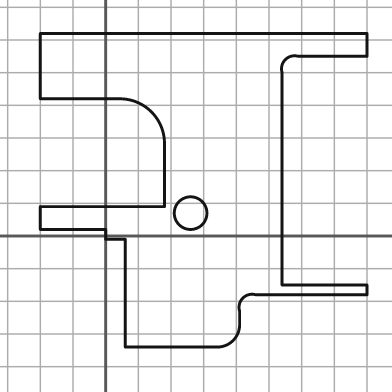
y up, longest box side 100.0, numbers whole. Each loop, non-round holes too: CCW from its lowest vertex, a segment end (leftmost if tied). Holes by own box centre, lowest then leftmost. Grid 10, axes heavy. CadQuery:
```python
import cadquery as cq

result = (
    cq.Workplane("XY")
    .moveTo(6.0, -34.0)
    .lineTo(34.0, -34.0)
    .threePointArc((39.0, -32.0), (41.0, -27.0))
    .lineTo(41.0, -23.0)
    .threePointArc((42.0, -19.0), (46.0, -18.0))
    .lineTo(80.0, -18.0)
    .lineTo(80.0, -15.0)
    .lineTo(54.0, -15.0)
    .lineTo(54.0, 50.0)
    .threePointArc((55.0, 54.0), (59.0, 55.0))
    .lineTo(80.0, 55.0)
    .lineTo(80.0, 62.0)
    .lineTo(-20.0, 62.0)
    .lineTo(-20.0, 42.0)
    .lineTo(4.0, 42.0)
    .threePointArc((14.0, 38.0), (18.0, 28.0))
    .lineTo(18.0, 9.0)
    .lineTo(-20.0, 9.0)
    .lineTo(-20.0, 2.0)
    .lineTo(0.0, 2.0)
    .lineTo(0.0, -1.0)
    .lineTo(6.0, -1.0)
    .close()
    .moveTo(26.0, 7.0)
    .circle(5.0)
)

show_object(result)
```